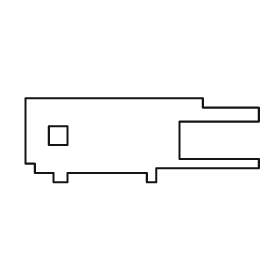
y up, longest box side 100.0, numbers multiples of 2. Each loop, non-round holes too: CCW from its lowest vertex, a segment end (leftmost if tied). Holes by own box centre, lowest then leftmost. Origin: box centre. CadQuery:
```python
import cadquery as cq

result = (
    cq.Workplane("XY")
    .moveTo(-38.0, -18.0)
    .lineTo(-32.0, -18.0)
    .lineTo(-32.0, -14.0)
    .lineTo(2.0, -14.0)
    .lineTo(2.0, -18.0)
    .lineTo(6.0, -18.0)
    .lineTo(6.0, -12.0)
    .lineTo(50.0, -12.0)
    .lineTo(50.0, -8.0)
    .lineTo(16.0, -8.0)
    .lineTo(16.0, 8.0)
    .lineTo(50.0, 8.0)
    .lineTo(50.0, 14.0)
    .lineTo(26.0, 14.0)
    .lineTo(26.0, 18.0)
    .lineTo(-50.0, 18.0)
    .lineTo(-50.0, -10.0)
    .lineTo(-46.0, -10.0)
    .lineTo(-46.0, -14.0)
    .lineTo(-38.0, -14.0)
    .close()
    .moveTo(-40.0, -2.0)
    .lineTo(-32.0, -2.0)
    .lineTo(-32.0, 6.0)
    .lineTo(-40.0, 6.0)
    .close()
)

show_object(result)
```